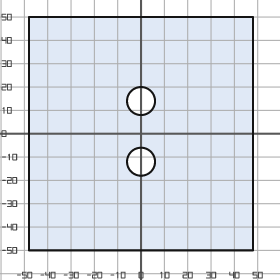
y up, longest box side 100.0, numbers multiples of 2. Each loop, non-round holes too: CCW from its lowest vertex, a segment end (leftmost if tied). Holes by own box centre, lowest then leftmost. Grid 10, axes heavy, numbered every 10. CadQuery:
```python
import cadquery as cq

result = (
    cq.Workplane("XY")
    .moveTo(-48.0, -50.0)
    .lineTo(48.0, -50.0)
    .lineTo(48.0, 50.0)
    .lineTo(-48.0, 50.0)
    .close()
    .moveTo(0.0, -12.0)
    .circle(6.0)
    .moveTo(0.0, 14.0)
    .circle(6.0)
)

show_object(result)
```